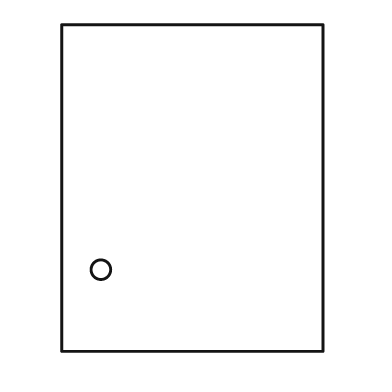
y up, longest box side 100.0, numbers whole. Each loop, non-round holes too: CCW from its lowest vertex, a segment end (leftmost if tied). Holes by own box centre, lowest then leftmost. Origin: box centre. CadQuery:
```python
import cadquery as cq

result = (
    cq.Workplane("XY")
    .moveTo(-40.0, -50.0)
    .lineTo(40.0, -50.0)
    .lineTo(40.0, 50.0)
    .lineTo(-40.0, 50.0)
    .close()
    .moveTo(-28.0, -25.0)
    .circle(3.0)
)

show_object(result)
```